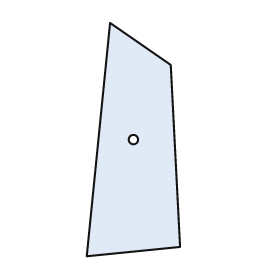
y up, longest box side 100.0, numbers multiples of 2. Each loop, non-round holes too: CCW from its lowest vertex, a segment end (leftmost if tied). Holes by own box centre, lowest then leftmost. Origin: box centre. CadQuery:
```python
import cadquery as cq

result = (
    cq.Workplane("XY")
    .moveTo(-20.0, -50.0)
    .lineTo(20.0, -46.0)
    .lineTo(16.0, 32.0)
    .lineTo(-10.0, 50.0)
    .close()
    .moveTo(0.0, 0.0)
    .circle(2.0)
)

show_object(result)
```